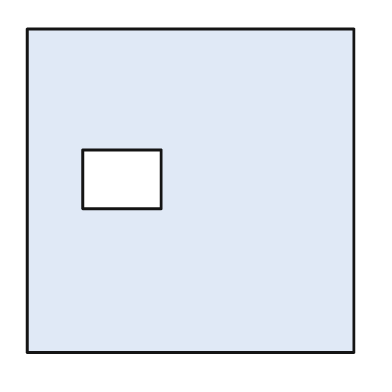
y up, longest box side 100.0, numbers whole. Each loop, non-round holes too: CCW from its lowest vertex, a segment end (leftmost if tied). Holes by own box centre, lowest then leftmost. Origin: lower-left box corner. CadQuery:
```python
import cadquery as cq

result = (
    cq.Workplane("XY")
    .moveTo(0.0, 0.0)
    .lineTo(100.0, 0.0)
    .lineTo(100.0, 99.0)
    .lineTo(0.0, 99.0)
    .close()
    .moveTo(17.0, 44.0)
    .lineTo(41.0, 44.0)
    .lineTo(41.0, 62.0)
    .lineTo(17.0, 62.0)
    .close()
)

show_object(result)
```